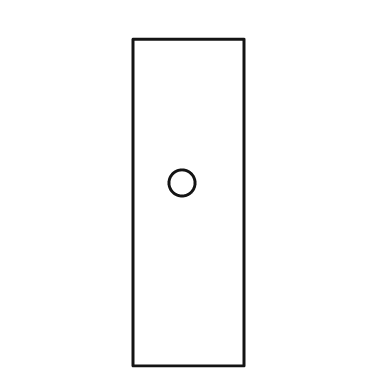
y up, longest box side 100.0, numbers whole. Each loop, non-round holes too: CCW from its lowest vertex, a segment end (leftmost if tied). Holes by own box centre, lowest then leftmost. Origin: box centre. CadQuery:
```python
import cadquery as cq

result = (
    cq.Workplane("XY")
    .moveTo(-17.0, -50.0)
    .lineTo(17.0, -50.0)
    .lineTo(17.0, 50.0)
    .lineTo(-17.0, 50.0)
    .close()
    .moveTo(-2.0, 6.0)
    .circle(4.0)
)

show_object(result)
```